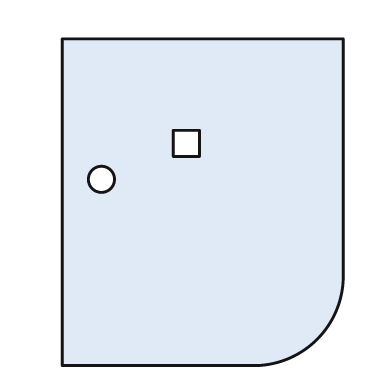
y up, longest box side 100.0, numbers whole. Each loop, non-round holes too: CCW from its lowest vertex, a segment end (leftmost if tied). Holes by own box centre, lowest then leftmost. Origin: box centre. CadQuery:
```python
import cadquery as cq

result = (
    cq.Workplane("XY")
    .moveTo(-43.0, -50.0)
    .lineTo(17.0, -50.0)
    .threePointArc((35.0, -42.0), (43.0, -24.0))
    .lineTo(43.0, 50.0)
    .lineTo(-43.0, 50.0)
    .close()
    .moveTo(-31.0, 7.0)
    .circle(4.0)
    .moveTo(-9.0, 14.0)
    .lineTo(-1.0, 14.0)
    .lineTo(-1.0, 22.0)
    .lineTo(-9.0, 22.0)
    .close()
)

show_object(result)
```